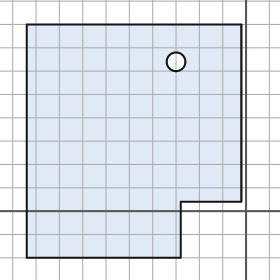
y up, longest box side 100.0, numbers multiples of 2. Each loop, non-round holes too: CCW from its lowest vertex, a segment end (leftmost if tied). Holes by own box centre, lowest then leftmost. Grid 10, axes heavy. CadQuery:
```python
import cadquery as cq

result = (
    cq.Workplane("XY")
    .moveTo(-94.0, -20.0)
    .lineTo(-28.0, -20.0)
    .lineTo(-28.0, 4.0)
    .lineTo(-2.0, 4.0)
    .lineTo(-2.0, 80.0)
    .lineTo(-94.0, 80.0)
    .close()
    .moveTo(-30.0, 64.0)
    .circle(4.0)
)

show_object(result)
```